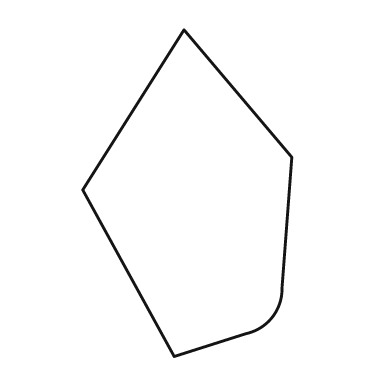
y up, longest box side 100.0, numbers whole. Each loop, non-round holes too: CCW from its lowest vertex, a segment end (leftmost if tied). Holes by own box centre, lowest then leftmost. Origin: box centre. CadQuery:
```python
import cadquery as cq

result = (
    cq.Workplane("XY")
    .moveTo(-4.0, -50.0)
    .lineTo(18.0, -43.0)
    .threePointArc((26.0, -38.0), (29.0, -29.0))
    .lineTo(32.0, 11.0)
    .lineTo(-1.0, 50.0)
    .lineTo(-32.0, 1.0)
    .close()
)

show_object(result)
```